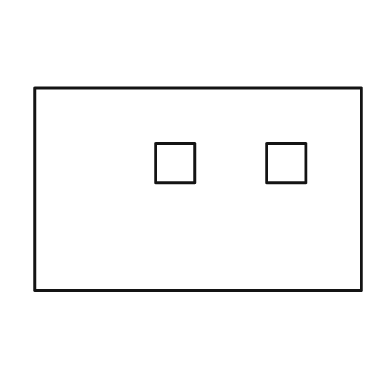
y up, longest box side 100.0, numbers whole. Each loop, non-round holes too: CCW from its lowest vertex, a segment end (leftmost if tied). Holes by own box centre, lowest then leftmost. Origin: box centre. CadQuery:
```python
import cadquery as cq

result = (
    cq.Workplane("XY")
    .moveTo(-50.0, -31.0)
    .lineTo(50.0, -31.0)
    .lineTo(50.0, 31.0)
    .lineTo(-50.0, 31.0)
    .close()
    .moveTo(-13.0, 2.0)
    .lineTo(-1.0, 2.0)
    .lineTo(-1.0, 14.0)
    .lineTo(-13.0, 14.0)
    .close()
    .moveTo(21.0, 2.0)
    .lineTo(33.0, 2.0)
    .lineTo(33.0, 14.0)
    .lineTo(21.0, 14.0)
    .close()
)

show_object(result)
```